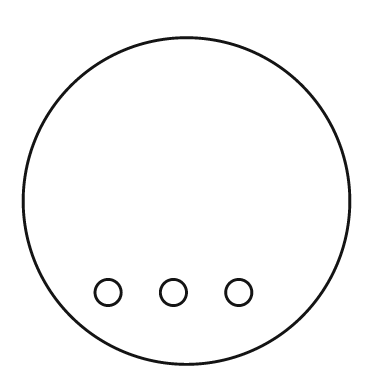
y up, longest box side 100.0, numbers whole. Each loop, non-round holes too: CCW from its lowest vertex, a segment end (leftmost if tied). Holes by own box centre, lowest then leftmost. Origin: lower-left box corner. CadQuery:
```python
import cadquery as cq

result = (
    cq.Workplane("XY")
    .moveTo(50.0, 50.0)
    .circle(50.0)
    .moveTo(26.0, 22.0)
    .circle(4.0)
    .moveTo(46.0, 22.0)
    .circle(4.0)
    .moveTo(66.0, 22.0)
    .circle(4.0)
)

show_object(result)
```